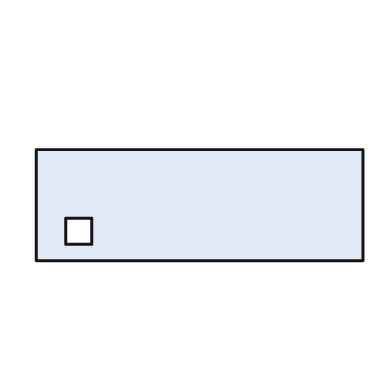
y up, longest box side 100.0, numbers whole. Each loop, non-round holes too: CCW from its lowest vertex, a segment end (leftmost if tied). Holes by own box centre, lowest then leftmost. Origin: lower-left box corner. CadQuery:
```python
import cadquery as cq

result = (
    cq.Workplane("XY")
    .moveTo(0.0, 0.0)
    .lineTo(100.0, 0.0)
    .lineTo(100.0, 34.0)
    .lineTo(0.0, 34.0)
    .close()
    .moveTo(9.0, 5.0)
    .lineTo(17.0, 5.0)
    .lineTo(17.0, 13.0)
    .lineTo(9.0, 13.0)
    .close()
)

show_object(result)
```